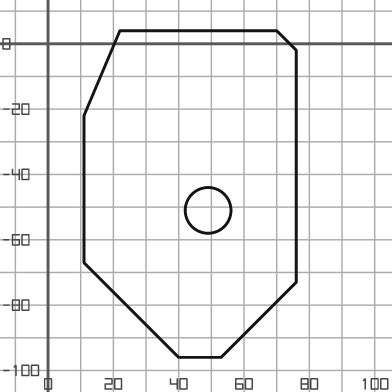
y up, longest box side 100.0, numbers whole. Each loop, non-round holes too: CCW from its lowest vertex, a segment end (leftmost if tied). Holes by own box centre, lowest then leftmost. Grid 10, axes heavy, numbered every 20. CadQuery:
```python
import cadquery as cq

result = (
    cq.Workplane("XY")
    .moveTo(40.0, -96.0)
    .lineTo(53.0, -96.0)
    .lineTo(76.0, -73.0)
    .lineTo(76.0, -2.0)
    .lineTo(70.0, 4.0)
    .lineTo(22.0, 4.0)
    .lineTo(11.0, -22.0)
    .lineTo(11.0, -67.0)
    .close()
    .moveTo(49.0, -51.0)
    .circle(7.0)
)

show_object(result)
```